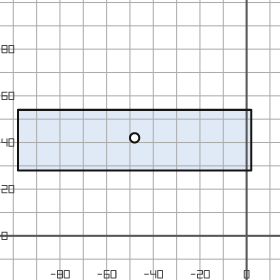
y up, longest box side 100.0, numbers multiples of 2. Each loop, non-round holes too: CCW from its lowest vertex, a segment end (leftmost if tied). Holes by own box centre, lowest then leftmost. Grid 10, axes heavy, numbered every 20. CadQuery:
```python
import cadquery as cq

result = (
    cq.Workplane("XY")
    .moveTo(-98.0, 28.0)
    .lineTo(2.0, 28.0)
    .lineTo(2.0, 54.0)
    .lineTo(-98.0, 54.0)
    .close()
    .moveTo(-48.0, 42.0)
    .circle(2.0)
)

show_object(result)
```